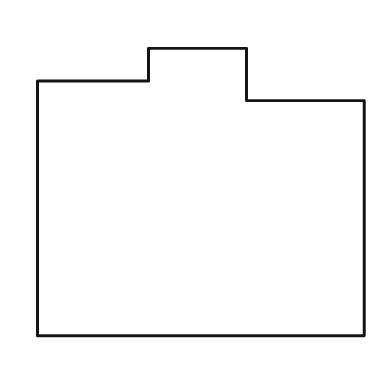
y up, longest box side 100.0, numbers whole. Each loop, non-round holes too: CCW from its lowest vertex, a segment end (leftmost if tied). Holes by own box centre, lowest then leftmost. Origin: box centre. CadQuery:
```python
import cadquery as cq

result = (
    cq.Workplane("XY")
    .moveTo(-50.0, -44.0)
    .lineTo(50.0, -44.0)
    .lineTo(50.0, 28.0)
    .lineTo(14.0, 28.0)
    .lineTo(14.0, 44.0)
    .lineTo(-16.0, 44.0)
    .lineTo(-16.0, 34.0)
    .lineTo(-50.0, 34.0)
    .close()
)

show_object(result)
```